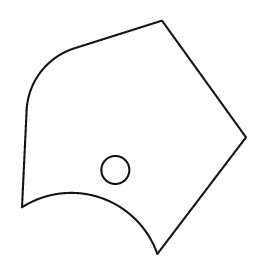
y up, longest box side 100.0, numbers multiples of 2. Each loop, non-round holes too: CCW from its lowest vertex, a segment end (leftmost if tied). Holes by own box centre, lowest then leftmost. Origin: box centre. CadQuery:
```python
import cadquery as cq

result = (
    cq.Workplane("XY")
    .moveTo(10.0, -50.0)
    .lineTo(48.0, 0.0)
    .lineTo(12.0, 50.0)
    .lineTo(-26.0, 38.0)
    .threePointArc((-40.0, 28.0), (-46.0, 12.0))
    .lineTo(-48.0, -30.0)
    .threePointArc((-14.0, -26.0), (10.0, -50.0))
    .close()
    .moveTo(-8.0, -14.0)
    .circle(6.0)
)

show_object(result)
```